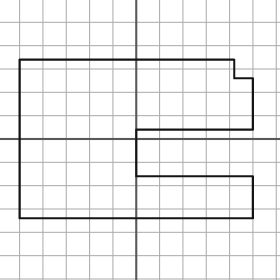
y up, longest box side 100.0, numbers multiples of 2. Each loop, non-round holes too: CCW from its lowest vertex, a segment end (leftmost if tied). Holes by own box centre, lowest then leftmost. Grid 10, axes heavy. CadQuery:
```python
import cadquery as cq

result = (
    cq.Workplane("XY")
    .moveTo(-50.0, -34.0)
    .lineTo(50.0, -34.0)
    .lineTo(50.0, -16.0)
    .lineTo(0.0, -16.0)
    .lineTo(0.0, 4.0)
    .lineTo(50.0, 4.0)
    .lineTo(50.0, 26.0)
    .lineTo(42.0, 26.0)
    .lineTo(42.0, 34.0)
    .lineTo(-50.0, 34.0)
    .close()
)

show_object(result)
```